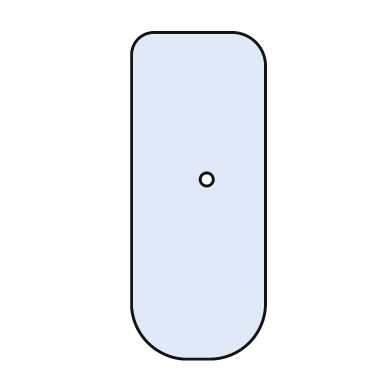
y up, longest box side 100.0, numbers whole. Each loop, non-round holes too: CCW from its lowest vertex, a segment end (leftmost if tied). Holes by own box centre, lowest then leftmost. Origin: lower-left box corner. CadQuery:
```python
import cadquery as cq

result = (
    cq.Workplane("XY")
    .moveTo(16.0, 0.0)
    .lineTo(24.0, 0.0)
    .threePointArc((36.0, 5.0), (41.0, 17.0))
    .lineTo(41.0, 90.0)
    .threePointArc((38.0, 97.0), (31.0, 100.0))
    .lineTo(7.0, 100.0)
    .threePointArc((2.0, 98.0), (0.0, 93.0))
    .lineTo(0.0, 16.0)
    .threePointArc((5.0, 5.0), (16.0, 0.0))
    .close()
    .moveTo(23.0, 55.0)
    .circle(2.0)
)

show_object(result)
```